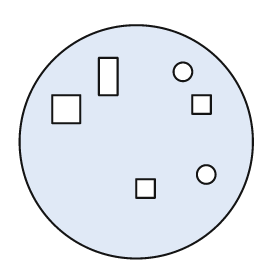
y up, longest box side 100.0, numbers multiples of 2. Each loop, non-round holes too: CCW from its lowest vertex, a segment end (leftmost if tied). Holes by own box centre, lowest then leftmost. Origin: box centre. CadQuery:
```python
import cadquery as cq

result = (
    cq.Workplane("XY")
    .moveTo(0.0, 0.0)
    .circle(50.0)
    .moveTo(0.0, -24.0)
    .lineTo(8.0, -24.0)
    .lineTo(8.0, -16.0)
    .lineTo(0.0, -16.0)
    .close()
    .moveTo(30.0, -14.0)
    .circle(4.0)
    .moveTo(-36.0, 8.0)
    .lineTo(-24.0, 8.0)
    .lineTo(-24.0, 20.0)
    .lineTo(-36.0, 20.0)
    .close()
    .moveTo(24.0, 12.0)
    .lineTo(32.0, 12.0)
    .lineTo(32.0, 20.0)
    .lineTo(24.0, 20.0)
    .close()
    .moveTo(-16.0, 20.0)
    .lineTo(-8.0, 20.0)
    .lineTo(-8.0, 36.0)
    .lineTo(-16.0, 36.0)
    .close()
    .moveTo(20.0, 30.0)
    .circle(4.0)
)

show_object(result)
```